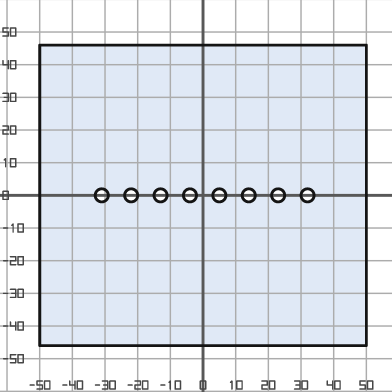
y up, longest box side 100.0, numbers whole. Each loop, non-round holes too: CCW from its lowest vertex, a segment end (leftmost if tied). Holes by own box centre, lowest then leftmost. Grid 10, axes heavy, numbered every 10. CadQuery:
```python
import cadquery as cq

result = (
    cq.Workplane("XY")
    .moveTo(-50.0, -46.0)
    .lineTo(50.0, -46.0)
    .lineTo(50.0, 46.0)
    .lineTo(-50.0, 46.0)
    .close()
    .moveTo(-31.0, 0.0)
    .circle(2.0)
    .moveTo(-22.0, 0.0)
    .circle(2.0)
    .moveTo(-13.0, 0.0)
    .circle(2.0)
    .moveTo(-4.0, 0.0)
    .circle(2.0)
    .moveTo(5.0, 0.0)
    .circle(2.0)
    .moveTo(14.0, 0.0)
    .circle(2.0)
    .moveTo(23.0, 0.0)
    .circle(2.0)
    .moveTo(32.0, 0.0)
    .circle(2.0)
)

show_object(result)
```